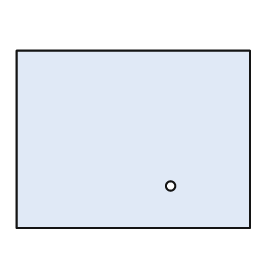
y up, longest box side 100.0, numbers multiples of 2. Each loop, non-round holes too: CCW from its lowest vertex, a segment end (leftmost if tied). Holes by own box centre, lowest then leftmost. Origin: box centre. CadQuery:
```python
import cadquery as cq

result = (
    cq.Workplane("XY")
    .moveTo(-50.0, -38.0)
    .lineTo(50.0, -38.0)
    .lineTo(50.0, 38.0)
    .lineTo(-50.0, 38.0)
    .close()
    .moveTo(16.0, -20.0)
    .circle(2.0)
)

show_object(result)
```